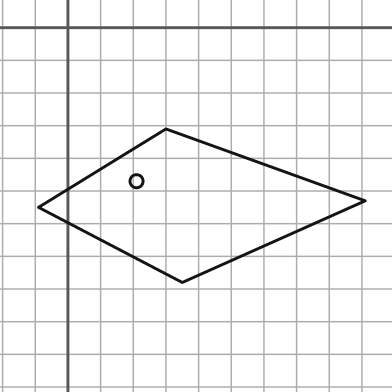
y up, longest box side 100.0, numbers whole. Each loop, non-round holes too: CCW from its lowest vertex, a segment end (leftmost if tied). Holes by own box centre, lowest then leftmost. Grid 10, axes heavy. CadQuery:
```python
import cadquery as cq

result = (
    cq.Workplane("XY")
    .moveTo(35.0, -78.0)
    .lineTo(91.0, -53.0)
    .lineTo(30.0, -31.0)
    .lineTo(-9.0, -55.0)
    .close()
    .moveTo(21.0, -47.0)
    .circle(2.0)
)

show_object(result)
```